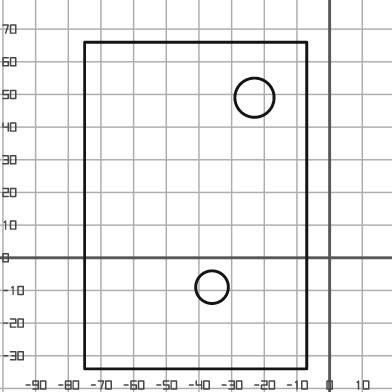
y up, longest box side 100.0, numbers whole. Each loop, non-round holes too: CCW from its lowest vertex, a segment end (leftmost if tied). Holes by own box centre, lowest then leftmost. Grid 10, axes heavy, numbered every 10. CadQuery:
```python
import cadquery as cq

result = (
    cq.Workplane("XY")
    .moveTo(-75.0, -34.0)
    .lineTo(-7.0, -34.0)
    .lineTo(-7.0, 66.0)
    .lineTo(-75.0, 66.0)
    .close()
    .moveTo(-36.0, -9.0)
    .circle(5.0)
    .moveTo(-23.0, 49.0)
    .circle(6.0)
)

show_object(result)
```